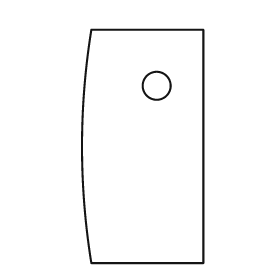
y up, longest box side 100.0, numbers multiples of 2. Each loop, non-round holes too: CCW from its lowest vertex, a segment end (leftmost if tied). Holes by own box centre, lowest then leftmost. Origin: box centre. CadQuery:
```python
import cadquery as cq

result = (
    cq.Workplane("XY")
    .moveTo(-22.0, -50.0)
    .lineTo(26.0, -50.0)
    .lineTo(26.0, 50.0)
    .lineTo(-22.0, 50.0)
    .threePointArc((-26.0, 0.0), (-22.0, -50.0))
    .close()
    .moveTo(6.0, 26.0)
    .circle(6.0)
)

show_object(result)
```